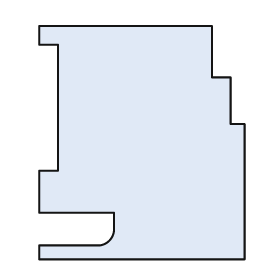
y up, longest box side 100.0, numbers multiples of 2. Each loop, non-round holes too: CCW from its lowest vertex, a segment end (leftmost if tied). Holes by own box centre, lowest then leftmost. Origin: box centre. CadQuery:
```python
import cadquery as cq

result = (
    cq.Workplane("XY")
    .moveTo(-44.0, -50.0)
    .lineTo(44.0, -50.0)
    .lineTo(44.0, 8.0)
    .lineTo(38.0, 8.0)
    .lineTo(38.0, 28.0)
    .lineTo(30.0, 28.0)
    .lineTo(30.0, 50.0)
    .lineTo(-44.0, 50.0)
    .lineTo(-44.0, 42.0)
    .lineTo(-36.0, 42.0)
    .lineTo(-36.0, -12.0)
    .lineTo(-44.0, -12.0)
    .lineTo(-44.0, -30.0)
    .lineTo(-12.0, -30.0)
    .lineTo(-12.0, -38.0)
    .threePointArc((-14.0, -42.0), (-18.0, -44.0))
    .lineTo(-44.0, -44.0)
    .close()
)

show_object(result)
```